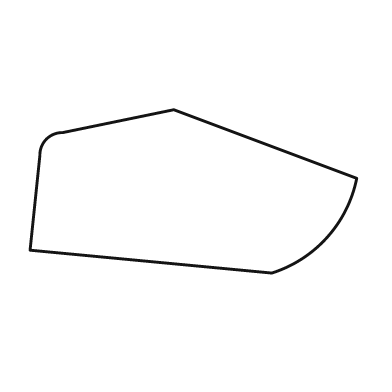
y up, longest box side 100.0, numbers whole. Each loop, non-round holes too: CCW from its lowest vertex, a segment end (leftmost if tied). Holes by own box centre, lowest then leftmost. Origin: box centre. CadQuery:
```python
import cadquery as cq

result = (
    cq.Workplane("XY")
    .moveTo(24.0, -25.0)
    .threePointArc((41.0, -14.0), (50.0, 4.0))
    .lineTo(-6.0, 25.0)
    .lineTo(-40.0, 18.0)
    .threePointArc((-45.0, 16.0), (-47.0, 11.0))
    .lineTo(-50.0, -18.0)
    .close()
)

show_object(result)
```